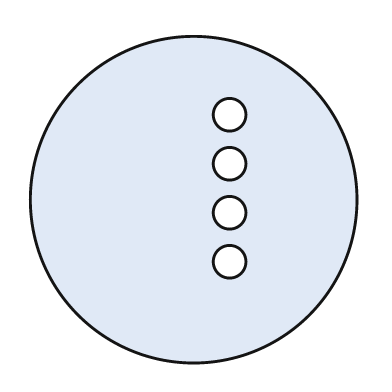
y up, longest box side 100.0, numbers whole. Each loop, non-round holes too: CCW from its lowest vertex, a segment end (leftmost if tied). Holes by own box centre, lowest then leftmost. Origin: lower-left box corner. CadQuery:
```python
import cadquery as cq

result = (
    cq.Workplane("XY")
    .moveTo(50.0, 50.0)
    .circle(50.0)
    .moveTo(61.0, 31.0)
    .circle(5.0)
    .moveTo(61.0, 46.0)
    .circle(5.0)
    .moveTo(61.0, 61.0)
    .circle(5.0)
    .moveTo(61.0, 76.0)
    .circle(5.0)
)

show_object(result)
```